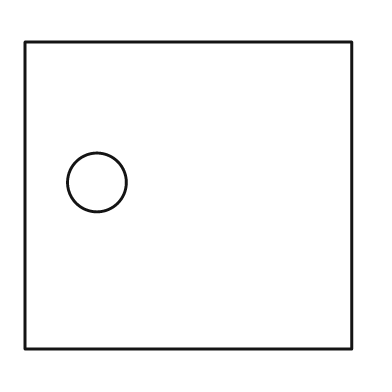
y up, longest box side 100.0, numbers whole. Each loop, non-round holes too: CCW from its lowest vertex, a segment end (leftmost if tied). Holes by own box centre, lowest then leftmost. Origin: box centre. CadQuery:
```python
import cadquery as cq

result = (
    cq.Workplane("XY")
    .moveTo(-50.0, -47.0)
    .lineTo(50.0, -47.0)
    .lineTo(50.0, 47.0)
    .lineTo(-50.0, 47.0)
    .close()
    .moveTo(-28.0, 4.0)
    .circle(9.0)
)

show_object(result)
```